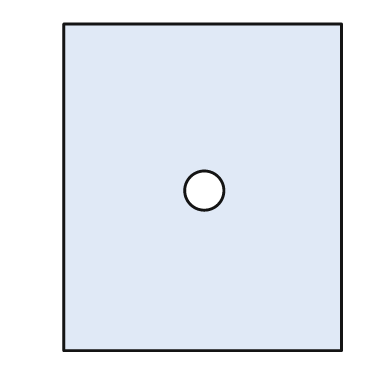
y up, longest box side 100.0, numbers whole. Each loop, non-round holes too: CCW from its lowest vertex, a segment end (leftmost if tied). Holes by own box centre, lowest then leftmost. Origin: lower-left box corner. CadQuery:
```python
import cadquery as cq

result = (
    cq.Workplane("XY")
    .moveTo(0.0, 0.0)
    .lineTo(85.0, 0.0)
    .lineTo(85.0, 100.0)
    .lineTo(0.0, 100.0)
    .close()
    .moveTo(43.0, 49.0)
    .circle(6.0)
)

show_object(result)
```